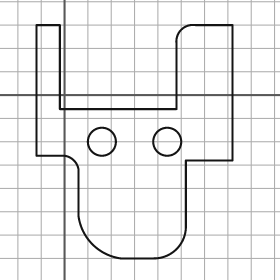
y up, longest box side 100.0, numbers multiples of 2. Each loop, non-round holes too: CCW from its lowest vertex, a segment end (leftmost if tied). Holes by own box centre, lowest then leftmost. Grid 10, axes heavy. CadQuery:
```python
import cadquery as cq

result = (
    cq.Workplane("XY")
    .moveTo(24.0, -70.0)
    .lineTo(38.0, -70.0)
    .threePointArc((48.0, -66.0), (52.0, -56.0))
    .lineTo(52.0, -28.0)
    .lineTo(72.0, -28.0)
    .lineTo(72.0, 30.0)
    .lineTo(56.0, 30.0)
    .threePointArc((50.0, 28.0), (48.0, 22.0))
    .lineTo(48.0, -6.0)
    .lineTo(-2.0, -6.0)
    .lineTo(-2.0, 30.0)
    .lineTo(-12.0, 30.0)
    .lineTo(-12.0, -26.0)
    .lineTo(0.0, -26.0)
    .threePointArc((4.0, -28.0), (6.0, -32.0))
    .lineTo(6.0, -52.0)
    .threePointArc((12.0, -64.0), (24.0, -70.0))
    .close()
    .moveTo(16.0, -20.0)
    .circle(6.0)
    .moveTo(44.0, -20.0)
    .circle(6.0)
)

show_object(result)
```